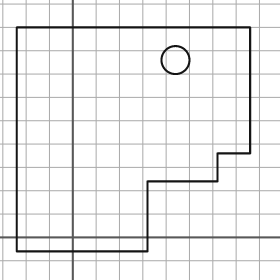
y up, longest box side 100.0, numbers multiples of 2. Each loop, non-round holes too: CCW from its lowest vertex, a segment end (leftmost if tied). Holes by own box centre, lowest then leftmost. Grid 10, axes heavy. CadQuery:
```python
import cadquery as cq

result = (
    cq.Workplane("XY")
    .moveTo(-24.0, -6.0)
    .lineTo(32.0, -6.0)
    .lineTo(32.0, 24.0)
    .lineTo(62.0, 24.0)
    .lineTo(62.0, 36.0)
    .lineTo(76.0, 36.0)
    .lineTo(76.0, 90.0)
    .lineTo(-24.0, 90.0)
    .close()
    .moveTo(44.0, 76.0)
    .circle(6.0)
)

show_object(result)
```